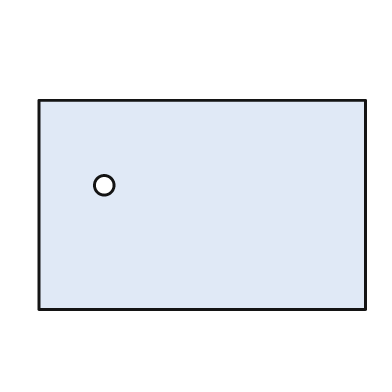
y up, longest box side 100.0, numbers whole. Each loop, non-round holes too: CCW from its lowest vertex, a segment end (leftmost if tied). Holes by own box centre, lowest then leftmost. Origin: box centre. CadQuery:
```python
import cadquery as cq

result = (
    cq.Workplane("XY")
    .moveTo(-50.0, -32.0)
    .lineTo(50.0, -32.0)
    .lineTo(50.0, 32.0)
    .lineTo(-50.0, 32.0)
    .close()
    .moveTo(-30.0, 6.0)
    .circle(3.0)
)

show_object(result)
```